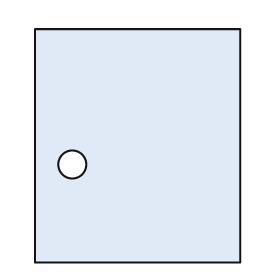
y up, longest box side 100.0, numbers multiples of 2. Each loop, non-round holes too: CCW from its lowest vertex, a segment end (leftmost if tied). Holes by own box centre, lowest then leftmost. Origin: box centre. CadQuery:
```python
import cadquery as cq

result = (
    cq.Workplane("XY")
    .moveTo(-44.0, -50.0)
    .lineTo(44.0, -50.0)
    .lineTo(44.0, 50.0)
    .lineTo(-44.0, 50.0)
    .close()
    .moveTo(-28.0, -8.0)
    .circle(6.0)
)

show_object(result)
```